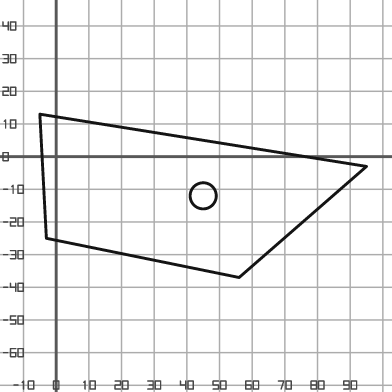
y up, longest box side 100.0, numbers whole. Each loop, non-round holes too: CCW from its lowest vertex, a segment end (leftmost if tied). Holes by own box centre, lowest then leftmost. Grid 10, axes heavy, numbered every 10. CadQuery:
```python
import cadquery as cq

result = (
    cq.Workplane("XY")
    .moveTo(56.0, -37.0)
    .lineTo(95.0, -3.0)
    .lineTo(-5.0, 13.0)
    .lineTo(-3.0, -25.0)
    .close()
    .moveTo(45.0, -12.0)
    .circle(4.0)
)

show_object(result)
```